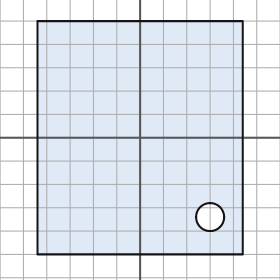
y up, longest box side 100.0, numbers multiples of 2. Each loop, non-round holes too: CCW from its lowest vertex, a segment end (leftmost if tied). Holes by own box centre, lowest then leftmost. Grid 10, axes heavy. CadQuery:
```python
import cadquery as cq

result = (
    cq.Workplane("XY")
    .moveTo(-44.0, -50.0)
    .lineTo(44.0, -50.0)
    .lineTo(44.0, 50.0)
    .lineTo(-44.0, 50.0)
    .close()
    .moveTo(30.0, -34.0)
    .circle(6.0)
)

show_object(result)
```